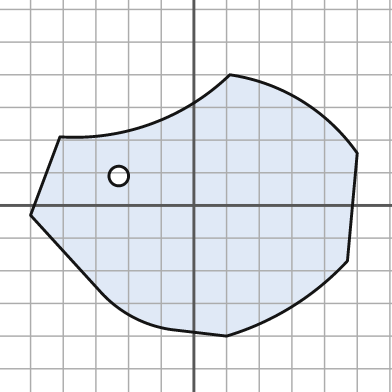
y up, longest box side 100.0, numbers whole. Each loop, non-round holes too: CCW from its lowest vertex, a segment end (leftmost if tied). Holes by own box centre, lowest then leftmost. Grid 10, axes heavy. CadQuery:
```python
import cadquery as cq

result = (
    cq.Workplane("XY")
    .moveTo(10.0, -40.0)
    .threePointArc((30.0, -31.0), (47.0, -17.0))
    .lineTo(50.0, 16.0)
    .threePointArc((33.0, 32.0), (11.0, 40.0))
    .threePointArc((-13.0, 25.0), (-41.0, 21.0))
    .lineTo(-50.0, -3.0)
    .lineTo(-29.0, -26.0)
    .threePointArc((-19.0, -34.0), (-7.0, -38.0))
    .close()
    .moveTo(-23.0, 9.0)
    .circle(3.0)
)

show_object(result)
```